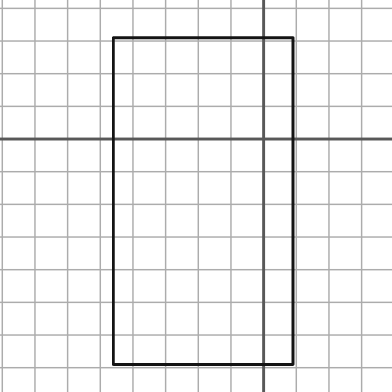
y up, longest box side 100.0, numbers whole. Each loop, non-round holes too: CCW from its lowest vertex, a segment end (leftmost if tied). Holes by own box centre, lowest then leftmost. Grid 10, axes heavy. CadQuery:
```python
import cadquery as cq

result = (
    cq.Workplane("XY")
    .moveTo(-46.0, -69.0)
    .lineTo(9.0, -69.0)
    .lineTo(9.0, 31.0)
    .lineTo(-46.0, 31.0)
    .close()
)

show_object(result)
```